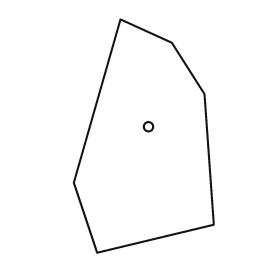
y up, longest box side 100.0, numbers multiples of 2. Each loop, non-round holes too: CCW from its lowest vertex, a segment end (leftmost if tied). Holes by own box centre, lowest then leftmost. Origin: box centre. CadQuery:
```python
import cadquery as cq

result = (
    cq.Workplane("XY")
    .moveTo(-20.0, -50.0)
    .lineTo(30.0, -38.0)
    .lineTo(26.0, 18.0)
    .lineTo(12.0, 40.0)
    .lineTo(-10.0, 50.0)
    .lineTo(-30.0, -20.0)
    .close()
    .moveTo(2.0, 4.0)
    .circle(2.0)
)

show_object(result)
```